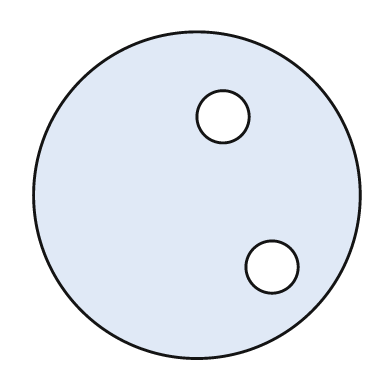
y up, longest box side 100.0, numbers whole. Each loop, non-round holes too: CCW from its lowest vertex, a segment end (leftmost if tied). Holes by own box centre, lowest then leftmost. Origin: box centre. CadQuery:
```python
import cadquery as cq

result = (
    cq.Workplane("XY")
    .moveTo(0.0, 0.0)
    .circle(50.0)
    .moveTo(23.0, -22.0)
    .circle(8.0)
    .moveTo(8.0, 24.0)
    .circle(8.0)
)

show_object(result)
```